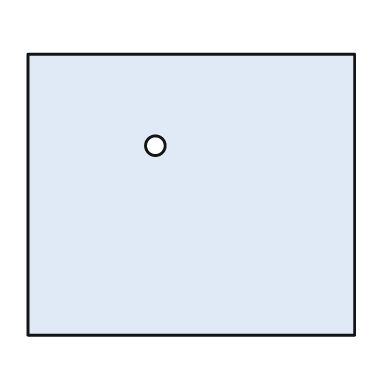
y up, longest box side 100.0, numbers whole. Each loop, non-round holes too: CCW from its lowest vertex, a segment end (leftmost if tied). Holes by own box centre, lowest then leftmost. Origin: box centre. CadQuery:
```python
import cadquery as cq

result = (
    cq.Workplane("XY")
    .moveTo(-50.0, -43.0)
    .lineTo(50.0, -43.0)
    .lineTo(50.0, 43.0)
    .lineTo(-50.0, 43.0)
    .close()
    .moveTo(-11.0, 15.0)
    .circle(3.0)
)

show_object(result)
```